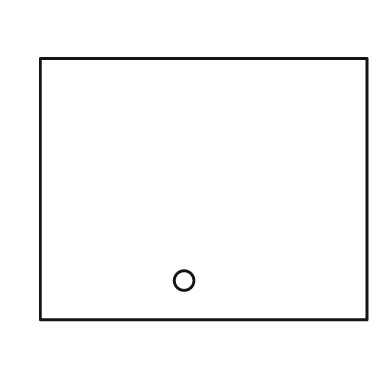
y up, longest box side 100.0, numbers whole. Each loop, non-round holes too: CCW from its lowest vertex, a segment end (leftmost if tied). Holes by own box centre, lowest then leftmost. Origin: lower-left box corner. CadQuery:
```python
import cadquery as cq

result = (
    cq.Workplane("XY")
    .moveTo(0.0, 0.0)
    .lineTo(100.0, 0.0)
    .lineTo(100.0, 80.0)
    .lineTo(0.0, 80.0)
    .close()
    .moveTo(44.0, 12.0)
    .circle(3.0)
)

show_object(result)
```